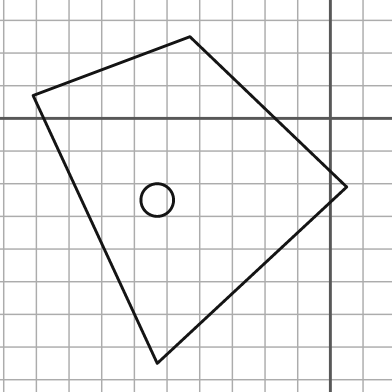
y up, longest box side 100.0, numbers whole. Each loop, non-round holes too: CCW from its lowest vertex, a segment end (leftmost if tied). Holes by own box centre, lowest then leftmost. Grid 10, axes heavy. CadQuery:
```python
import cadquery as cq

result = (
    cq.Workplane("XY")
    .moveTo(-53.0, -75.0)
    .lineTo(5.0, -21.0)
    .lineTo(-43.0, 25.0)
    .lineTo(-91.0, 7.0)
    .close()
    .moveTo(-53.0, -25.0)
    .circle(5.0)
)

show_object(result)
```